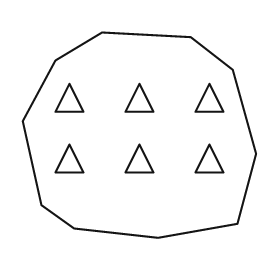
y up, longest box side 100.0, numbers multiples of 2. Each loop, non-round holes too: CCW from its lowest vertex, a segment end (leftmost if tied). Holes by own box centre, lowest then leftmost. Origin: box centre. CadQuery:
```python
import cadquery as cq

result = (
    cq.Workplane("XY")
    .moveTo(8.0, -44.0)
    .lineTo(42.0, -38.0)
    .lineTo(50.0, -8.0)
    .lineTo(40.0, 28.0)
    .lineTo(22.0, 42.0)
    .lineTo(-16.0, 44.0)
    .lineTo(-36.0, 32.0)
    .lineTo(-50.0, 6.0)
    .lineTo(-42.0, -30.0)
    .lineTo(-28.0, -40.0)
    .close()
    .moveTo(-36.0, -16.0)
    .lineTo(-24.0, -16.0)
    .lineTo(-30.0, -4.0)
    .close()
    .moveTo(-6.0, -16.0)
    .lineTo(6.0, -16.0)
    .lineTo(0.0, -4.0)
    .close()
    .moveTo(24.0, -16.0)
    .lineTo(36.0, -16.0)
    .lineTo(30.0, -4.0)
    .close()
    .moveTo(-36.0, 10.0)
    .lineTo(-24.0, 10.0)
    .lineTo(-30.0, 22.0)
    .close()
    .moveTo(-6.0, 10.0)
    .lineTo(6.0, 10.0)
    .lineTo(0.0, 22.0)
    .close()
    .moveTo(24.0, 10.0)
    .lineTo(36.0, 10.0)
    .lineTo(30.0, 22.0)
    .close()
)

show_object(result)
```